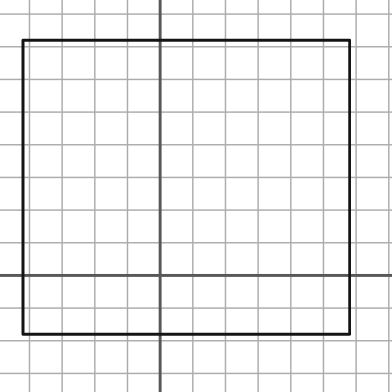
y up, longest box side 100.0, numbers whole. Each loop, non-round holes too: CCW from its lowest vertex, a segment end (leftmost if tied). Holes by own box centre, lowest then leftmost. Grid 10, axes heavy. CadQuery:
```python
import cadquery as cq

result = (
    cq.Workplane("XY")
    .moveTo(-42.0, -18.0)
    .lineTo(58.0, -18.0)
    .lineTo(58.0, 72.0)
    .lineTo(-42.0, 72.0)
    .close()
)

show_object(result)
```